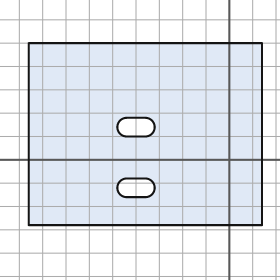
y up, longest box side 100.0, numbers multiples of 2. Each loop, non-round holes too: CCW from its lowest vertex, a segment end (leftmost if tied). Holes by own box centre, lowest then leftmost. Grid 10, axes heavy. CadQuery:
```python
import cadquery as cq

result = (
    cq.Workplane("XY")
    .moveTo(-86.0, -28.0)
    .lineTo(14.0, -28.0)
    .lineTo(14.0, 50.0)
    .lineTo(-86.0, 50.0)
    .close()
    .moveTo(-44.0, -16.0)
    .lineTo(-36.0, -16.0)
    .threePointArc((-32.0, -12.0), (-36.0, -8.0))
    .lineTo(-44.0, -8.0)
    .threePointArc((-48.0, -12.0), (-44.0, -16.0))
    .close()
    .moveTo(-44.0, 10.0)
    .lineTo(-36.0, 10.0)
    .threePointArc((-32.0, 14.0), (-36.0, 18.0))
    .lineTo(-44.0, 18.0)
    .threePointArc((-48.0, 14.0), (-44.0, 10.0))
    .close()
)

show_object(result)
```